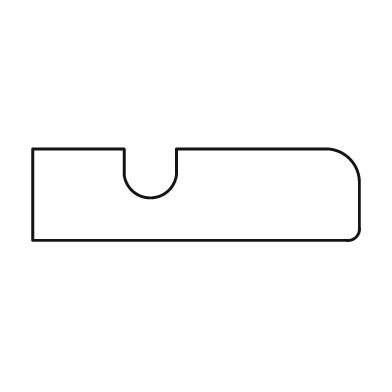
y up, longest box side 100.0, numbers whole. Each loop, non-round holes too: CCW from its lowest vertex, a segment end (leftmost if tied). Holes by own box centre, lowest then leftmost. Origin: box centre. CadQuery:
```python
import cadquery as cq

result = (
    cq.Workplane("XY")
    .moveTo(-50.0, -14.0)
    .lineTo(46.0, -14.0)
    .threePointArc((49.0, -13.0), (50.0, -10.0))
    .lineTo(50.0, 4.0)
    .threePointArc((47.0, 11.0), (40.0, 14.0))
    .lineTo(-6.0, 14.0)
    .lineTo(-6.0, 6.0)
    .threePointArc((-14.0, -1.0), (-22.0, 6.0))
    .lineTo(-22.0, 14.0)
    .lineTo(-50.0, 14.0)
    .close()
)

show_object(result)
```